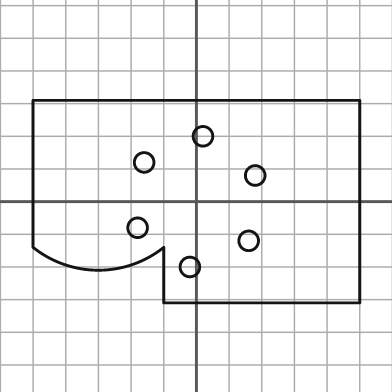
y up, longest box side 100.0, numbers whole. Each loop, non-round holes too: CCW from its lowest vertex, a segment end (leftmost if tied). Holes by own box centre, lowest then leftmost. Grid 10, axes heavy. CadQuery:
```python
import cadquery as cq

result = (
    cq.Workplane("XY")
    .moveTo(-10.0, -31.0)
    .lineTo(50.0, -31.0)
    .lineTo(50.0, 31.0)
    .lineTo(-50.0, 31.0)
    .lineTo(-50.0, -14.0)
    .threePointArc((-30.0, -21.0), (-10.0, -14.0))
    .close()
    .moveTo(-2.0, -20.0)
    .circle(3.0)
    .moveTo(16.0, -12.0)
    .circle(3.0)
    .moveTo(-18.0, -8.0)
    .circle(3.0)
    .moveTo(18.0, 8.0)
    .circle(3.0)
    .moveTo(-16.0, 12.0)
    .circle(3.0)
    .moveTo(2.0, 20.0)
    .circle(3.0)
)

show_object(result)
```